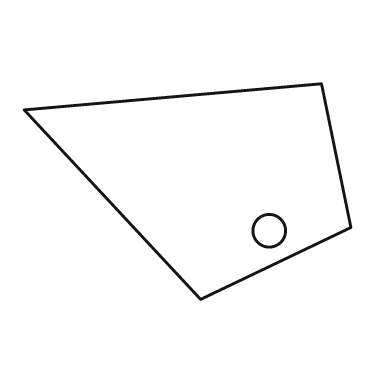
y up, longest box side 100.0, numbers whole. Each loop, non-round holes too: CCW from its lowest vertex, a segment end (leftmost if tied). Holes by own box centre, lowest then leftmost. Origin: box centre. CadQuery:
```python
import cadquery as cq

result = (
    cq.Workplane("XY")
    .moveTo(4.0, -33.0)
    .lineTo(50.0, -11.0)
    .lineTo(41.0, 33.0)
    .lineTo(-50.0, 25.0)
    .close()
    .moveTo(25.0, -12.0)
    .circle(5.0)
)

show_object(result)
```